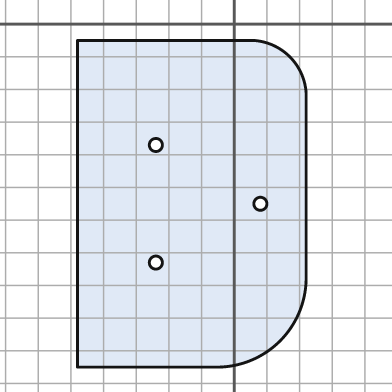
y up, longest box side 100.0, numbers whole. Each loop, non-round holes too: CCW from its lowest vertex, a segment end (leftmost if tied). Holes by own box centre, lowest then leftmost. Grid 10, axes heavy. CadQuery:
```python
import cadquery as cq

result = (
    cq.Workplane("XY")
    .moveTo(-48.0, -105.0)
    .lineTo(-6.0, -105.0)
    .threePointArc((14.0, -97.0), (22.0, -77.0))
    .lineTo(22.0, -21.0)
    .threePointArc((17.0, -10.0), (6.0, -5.0))
    .lineTo(-48.0, -5.0)
    .close()
    .moveTo(-24.0, -73.0)
    .circle(2.0)
    .moveTo(8.0, -55.0)
    .circle(2.0)
    .moveTo(-24.0, -37.0)
    .circle(2.0)
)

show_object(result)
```